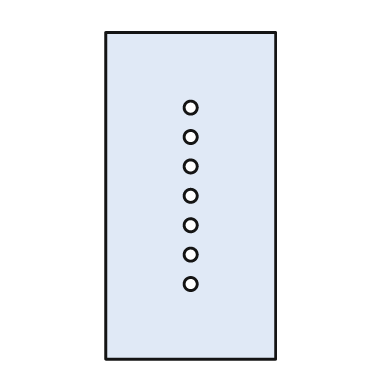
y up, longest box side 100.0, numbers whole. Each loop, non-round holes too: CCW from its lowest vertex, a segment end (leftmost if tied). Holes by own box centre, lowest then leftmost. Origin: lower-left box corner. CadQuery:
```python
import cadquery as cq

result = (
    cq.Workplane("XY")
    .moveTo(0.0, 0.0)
    .lineTo(52.0, 0.0)
    .lineTo(52.0, 100.0)
    .lineTo(0.0, 100.0)
    .close()
    .moveTo(26.0, 23.0)
    .circle(2.0)
    .moveTo(26.0, 32.0)
    .circle(2.0)
    .moveTo(26.0, 41.0)
    .circle(2.0)
    .moveTo(26.0, 50.0)
    .circle(2.0)
    .moveTo(26.0, 59.0)
    .circle(2.0)
    .moveTo(26.0, 68.0)
    .circle(2.0)
    .moveTo(26.0, 77.0)
    .circle(2.0)
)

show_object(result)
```